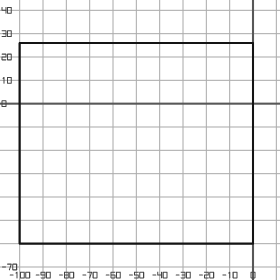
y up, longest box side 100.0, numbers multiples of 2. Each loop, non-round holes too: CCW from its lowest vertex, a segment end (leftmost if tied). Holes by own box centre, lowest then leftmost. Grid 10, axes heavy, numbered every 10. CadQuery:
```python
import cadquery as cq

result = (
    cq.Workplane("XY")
    .moveTo(-100.0, -60.0)
    .lineTo(0.0, -60.0)
    .lineTo(0.0, 26.0)
    .lineTo(-100.0, 26.0)
    .close()
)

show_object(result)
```